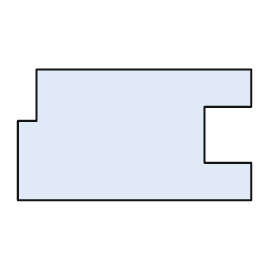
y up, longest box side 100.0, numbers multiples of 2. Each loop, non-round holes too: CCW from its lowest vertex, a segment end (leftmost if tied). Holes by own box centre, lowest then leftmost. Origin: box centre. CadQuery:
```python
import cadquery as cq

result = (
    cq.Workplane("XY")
    .moveTo(-50.0, -28.0)
    .lineTo(50.0, -28.0)
    .lineTo(50.0, -12.0)
    .lineTo(30.0, -12.0)
    .lineTo(30.0, 12.0)
    .lineTo(50.0, 12.0)
    .lineTo(50.0, 28.0)
    .lineTo(-42.0, 28.0)
    .lineTo(-42.0, 6.0)
    .lineTo(-50.0, 6.0)
    .close()
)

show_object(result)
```